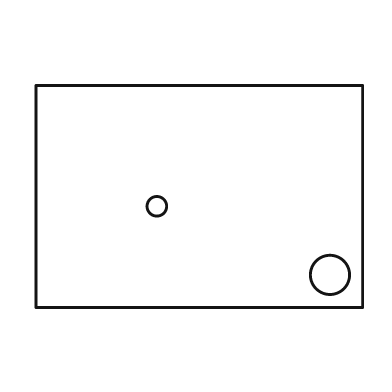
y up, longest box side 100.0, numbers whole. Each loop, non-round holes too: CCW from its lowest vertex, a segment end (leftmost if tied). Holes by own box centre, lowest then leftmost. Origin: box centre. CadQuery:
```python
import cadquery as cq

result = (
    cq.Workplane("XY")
    .moveTo(-50.0, -34.0)
    .lineTo(50.0, -34.0)
    .lineTo(50.0, 34.0)
    .lineTo(-50.0, 34.0)
    .close()
    .moveTo(40.0, -24.0)
    .circle(6.0)
    .moveTo(-13.0, -3.0)
    .circle(3.0)
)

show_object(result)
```